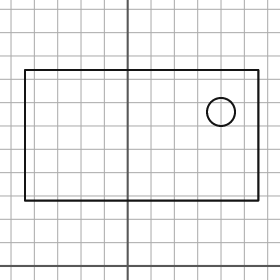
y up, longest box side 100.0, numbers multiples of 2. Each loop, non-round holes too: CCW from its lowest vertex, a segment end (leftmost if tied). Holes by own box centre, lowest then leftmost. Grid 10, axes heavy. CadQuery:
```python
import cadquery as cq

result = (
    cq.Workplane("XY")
    .moveTo(-44.0, 28.0)
    .lineTo(56.0, 28.0)
    .lineTo(56.0, 84.0)
    .lineTo(-44.0, 84.0)
    .close()
    .moveTo(40.0, 66.0)
    .circle(6.0)
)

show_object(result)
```